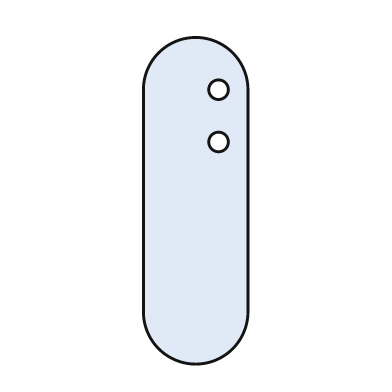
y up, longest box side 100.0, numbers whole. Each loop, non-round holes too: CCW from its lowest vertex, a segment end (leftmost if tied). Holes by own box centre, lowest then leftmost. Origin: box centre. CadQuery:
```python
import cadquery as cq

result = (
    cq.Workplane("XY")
    .moveTo(-16.0, -34.0)
    .threePointArc((0.0, -50.0), (16.0, -34.0))
    .lineTo(16.0, 34.0)
    .threePointArc((0.0, 50.0), (-16.0, 34.0))
    .close()
    .moveTo(7.0, 18.0)
    .circle(3.0)
    .moveTo(7.0, 34.0)
    .circle(3.0)
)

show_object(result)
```